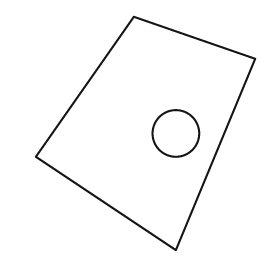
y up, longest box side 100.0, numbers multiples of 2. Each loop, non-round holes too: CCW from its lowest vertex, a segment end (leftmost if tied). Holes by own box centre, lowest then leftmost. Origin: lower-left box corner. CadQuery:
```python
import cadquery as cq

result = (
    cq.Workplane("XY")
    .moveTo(60.0, 0.0)
    .lineTo(94.0, 82.0)
    .lineTo(42.0, 100.0)
    .lineTo(0.0, 40.0)
    .close()
    .moveTo(60.0, 50.0)
    .circle(10.0)
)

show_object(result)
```